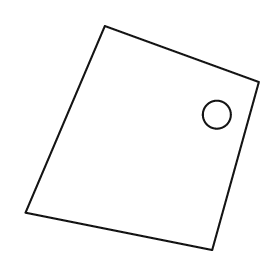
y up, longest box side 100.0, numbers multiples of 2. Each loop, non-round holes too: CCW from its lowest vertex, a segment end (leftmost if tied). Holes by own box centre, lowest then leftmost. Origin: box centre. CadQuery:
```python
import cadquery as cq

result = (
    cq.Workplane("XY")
    .moveTo(30.0, -48.0)
    .lineTo(50.0, 24.0)
    .lineTo(-16.0, 48.0)
    .lineTo(-50.0, -32.0)
    .close()
    .moveTo(32.0, 10.0)
    .circle(6.0)
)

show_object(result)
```